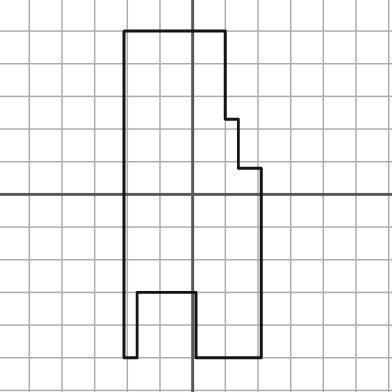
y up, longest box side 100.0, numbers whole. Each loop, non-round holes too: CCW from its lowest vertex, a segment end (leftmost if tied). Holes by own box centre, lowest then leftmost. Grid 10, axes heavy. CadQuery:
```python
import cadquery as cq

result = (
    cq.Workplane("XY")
    .moveTo(-21.0, -50.0)
    .lineTo(-17.0, -50.0)
    .lineTo(-17.0, -30.0)
    .lineTo(1.0, -30.0)
    .lineTo(1.0, -50.0)
    .lineTo(21.0, -50.0)
    .lineTo(21.0, 8.0)
    .lineTo(14.0, 8.0)
    .lineTo(14.0, 23.0)
    .lineTo(10.0, 23.0)
    .lineTo(10.0, 50.0)
    .lineTo(-21.0, 50.0)
    .close()
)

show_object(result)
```